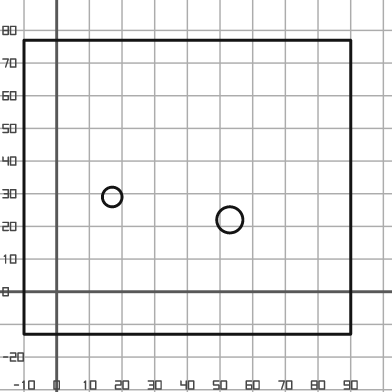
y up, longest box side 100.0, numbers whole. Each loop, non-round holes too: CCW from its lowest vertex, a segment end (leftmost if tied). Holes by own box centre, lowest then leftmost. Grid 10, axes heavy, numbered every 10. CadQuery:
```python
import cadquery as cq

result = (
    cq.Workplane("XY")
    .moveTo(-10.0, -13.0)
    .lineTo(90.0, -13.0)
    .lineTo(90.0, 77.0)
    .lineTo(-10.0, 77.0)
    .close()
    .moveTo(53.0, 22.0)
    .circle(4.0)
    .moveTo(17.0, 29.0)
    .circle(3.0)
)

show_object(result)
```